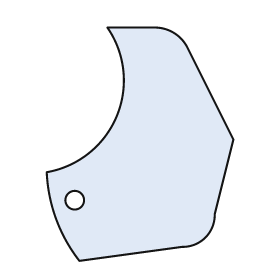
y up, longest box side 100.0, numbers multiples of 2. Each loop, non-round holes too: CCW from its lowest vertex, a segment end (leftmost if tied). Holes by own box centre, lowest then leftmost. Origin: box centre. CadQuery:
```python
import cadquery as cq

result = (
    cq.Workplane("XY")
    .moveTo(-26.0, -50.0)
    .lineTo(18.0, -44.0)
    .threePointArc((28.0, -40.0), (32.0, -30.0))
    .lineTo(40.0, 2.0)
    .lineTo(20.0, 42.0)
    .threePointArc((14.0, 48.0), (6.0, 50.0))
    .lineTo(-14.0, 50.0)
    .threePointArc((-10.0, 12.0), (-40.0, -12.0))
    .threePointArc((-36.0, -32.0), (-26.0, -50.0))
    .close()
    .moveTo(-28.0, -24.0)
    .circle(4.0)
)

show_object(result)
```